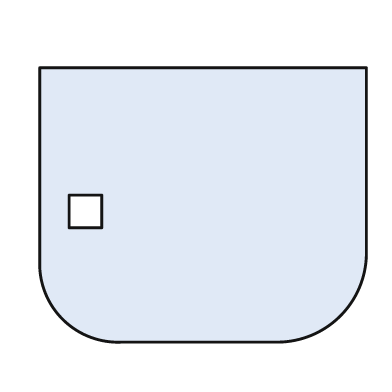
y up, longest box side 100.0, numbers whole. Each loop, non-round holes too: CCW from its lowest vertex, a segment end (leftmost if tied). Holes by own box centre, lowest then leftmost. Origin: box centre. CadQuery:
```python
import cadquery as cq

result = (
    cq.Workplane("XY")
    .moveTo(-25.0, -42.0)
    .lineTo(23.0, -42.0)
    .threePointArc((42.0, -34.0), (50.0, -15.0))
    .lineTo(50.0, 42.0)
    .lineTo(-50.0, 42.0)
    .lineTo(-50.0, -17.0)
    .threePointArc((-43.0, -35.0), (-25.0, -42.0))
    .close()
    .moveTo(-41.0, -7.0)
    .lineTo(-31.0, -7.0)
    .lineTo(-31.0, 3.0)
    .lineTo(-41.0, 3.0)
    .close()
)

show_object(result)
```